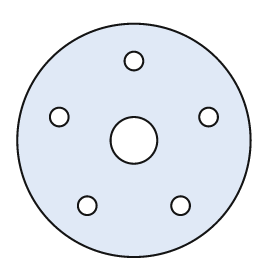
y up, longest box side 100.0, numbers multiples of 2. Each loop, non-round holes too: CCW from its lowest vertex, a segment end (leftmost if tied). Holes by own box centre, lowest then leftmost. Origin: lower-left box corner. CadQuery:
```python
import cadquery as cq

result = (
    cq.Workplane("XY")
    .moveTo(50.0, 50.0)
    .circle(50.0)
    .moveTo(30.0, 22.0)
    .circle(4.0)
    .moveTo(70.0, 22.0)
    .circle(4.0)
    .moveTo(50.0, 50.0)
    .circle(10.0)
    .moveTo(18.0, 60.0)
    .circle(4.0)
    .moveTo(82.0, 60.0)
    .circle(4.0)
    .moveTo(50.0, 84.0)
    .circle(4.0)
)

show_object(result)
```